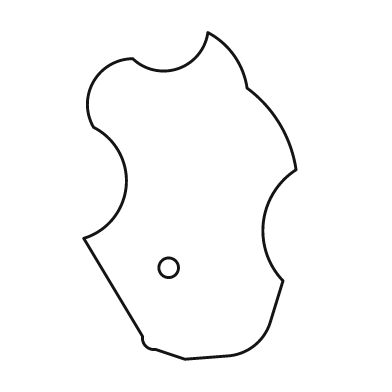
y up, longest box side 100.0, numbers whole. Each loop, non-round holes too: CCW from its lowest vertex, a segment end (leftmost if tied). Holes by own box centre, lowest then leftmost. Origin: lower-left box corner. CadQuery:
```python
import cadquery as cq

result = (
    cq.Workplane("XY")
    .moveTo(31.0, 0.0)
    .lineTo(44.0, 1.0)
    .threePointArc((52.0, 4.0), (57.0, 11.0))
    .lineTo(61.0, 24.0)
    .threePointArc((55.0, 42.0), (65.0, 58.0))
    .threePointArc((60.0, 72.0), (50.0, 83.0))
    .threePointArc((46.0, 93.0), (38.0, 100.0))
    .threePointArc((29.0, 89.0), (15.0, 92.0))
    .threePointArc((3.0, 85.0), (3.0, 71.0))
    .threePointArc((13.0, 53.0), (0.0, 37.0))
    .lineTo(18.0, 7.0)
    .threePointArc((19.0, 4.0), (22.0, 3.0))
    .close()
    .moveTo(26.0, 28.0)
    .circle(3.0)
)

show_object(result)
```